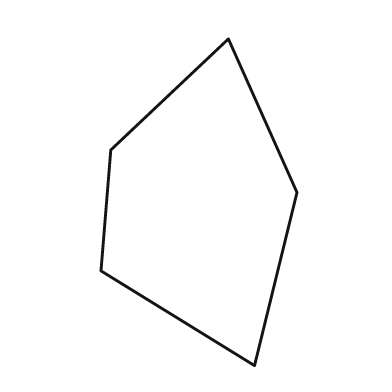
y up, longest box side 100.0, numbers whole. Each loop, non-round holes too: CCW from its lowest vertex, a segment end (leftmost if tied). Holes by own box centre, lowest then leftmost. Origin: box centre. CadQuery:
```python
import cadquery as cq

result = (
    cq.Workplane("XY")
    .moveTo(17.0, -50.0)
    .lineTo(30.0, 3.0)
    .lineTo(9.0, 50.0)
    .lineTo(-27.0, 16.0)
    .lineTo(-30.0, -21.0)
    .close()
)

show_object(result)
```